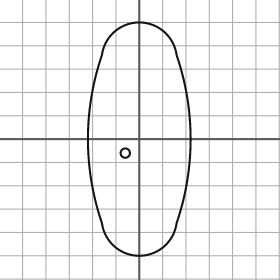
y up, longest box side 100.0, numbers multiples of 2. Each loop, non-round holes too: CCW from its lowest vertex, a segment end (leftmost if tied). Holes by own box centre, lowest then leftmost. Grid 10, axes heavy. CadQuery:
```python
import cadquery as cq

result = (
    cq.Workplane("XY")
    .moveTo(-16.0, -36.0)
    .threePointArc((0.0, -50.0), (16.0, -36.0))
    .threePointArc((22.0, 0.0), (16.0, 36.0))
    .threePointArc((0.0, 50.0), (-16.0, 36.0))
    .threePointArc((-22.0, 0.0), (-16.0, -36.0))
    .close()
    .moveTo(-6.0, -6.0)
    .circle(2.0)
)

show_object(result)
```